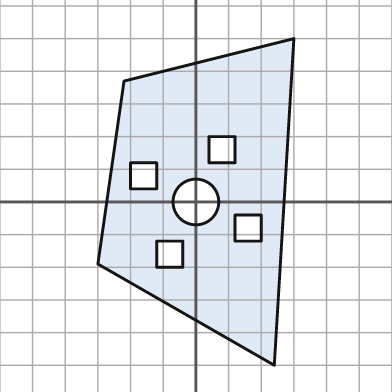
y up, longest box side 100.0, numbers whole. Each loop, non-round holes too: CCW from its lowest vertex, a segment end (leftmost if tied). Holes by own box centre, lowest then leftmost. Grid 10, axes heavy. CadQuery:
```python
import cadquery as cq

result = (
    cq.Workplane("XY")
    .moveTo(24.0, -50.0)
    .lineTo(30.0, 50.0)
    .lineTo(-22.0, 37.0)
    .lineTo(-30.0, -19.0)
    .close()
    .moveTo(-12.0, -20.0)
    .lineTo(-4.0, -20.0)
    .lineTo(-4.0, -12.0)
    .lineTo(-12.0, -12.0)
    .close()
    .moveTo(12.0, -12.0)
    .lineTo(20.0, -12.0)
    .lineTo(20.0, -4.0)
    .lineTo(12.0, -4.0)
    .close()
    .moveTo(0.0, 0.0)
    .circle(7.0)
    .moveTo(-20.0, 4.0)
    .lineTo(-12.0, 4.0)
    .lineTo(-12.0, 12.0)
    .lineTo(-20.0, 12.0)
    .close()
    .moveTo(4.0, 12.0)
    .lineTo(12.0, 12.0)
    .lineTo(12.0, 20.0)
    .lineTo(4.0, 20.0)
    .close()
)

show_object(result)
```